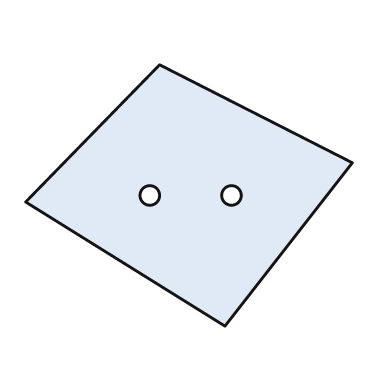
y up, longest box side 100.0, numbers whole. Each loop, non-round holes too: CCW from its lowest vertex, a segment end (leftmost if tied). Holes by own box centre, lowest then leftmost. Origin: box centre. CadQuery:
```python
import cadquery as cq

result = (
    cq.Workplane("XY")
    .moveTo(11.0, -40.0)
    .lineTo(50.0, 10.0)
    .lineTo(-9.0, 40.0)
    .lineTo(-50.0, -2.0)
    .close()
    .moveTo(-12.0, 0.0)
    .circle(3.0)
    .moveTo(13.0, 0.0)
    .circle(3.0)
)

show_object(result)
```